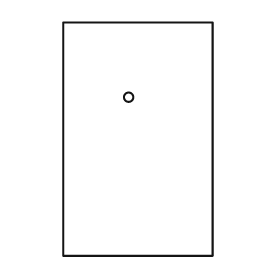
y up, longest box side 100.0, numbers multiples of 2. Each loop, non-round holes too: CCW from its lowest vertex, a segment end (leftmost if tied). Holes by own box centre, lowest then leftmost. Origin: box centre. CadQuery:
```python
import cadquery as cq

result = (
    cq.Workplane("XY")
    .moveTo(-32.0, -50.0)
    .lineTo(32.0, -50.0)
    .lineTo(32.0, 50.0)
    .lineTo(-32.0, 50.0)
    .close()
    .moveTo(-4.0, 18.0)
    .circle(2.0)
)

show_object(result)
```